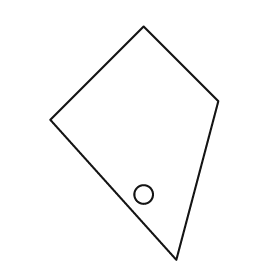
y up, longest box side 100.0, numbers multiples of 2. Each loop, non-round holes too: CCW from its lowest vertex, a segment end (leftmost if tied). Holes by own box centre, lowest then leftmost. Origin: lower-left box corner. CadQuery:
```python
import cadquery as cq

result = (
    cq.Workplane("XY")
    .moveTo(54.0, 0.0)
    .lineTo(72.0, 68.0)
    .lineTo(40.0, 100.0)
    .lineTo(0.0, 60.0)
    .close()
    .moveTo(40.0, 28.0)
    .circle(4.0)
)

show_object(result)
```